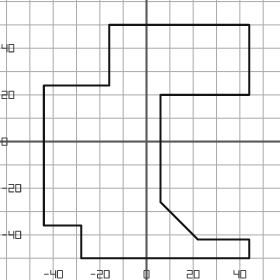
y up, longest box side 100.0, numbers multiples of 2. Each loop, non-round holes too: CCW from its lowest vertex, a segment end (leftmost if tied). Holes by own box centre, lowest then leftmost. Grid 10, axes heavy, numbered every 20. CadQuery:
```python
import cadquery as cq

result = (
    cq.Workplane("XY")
    .moveTo(-28.0, -50.0)
    .lineTo(44.0, -50.0)
    .lineTo(44.0, -42.0)
    .lineTo(22.0, -42.0)
    .lineTo(6.0, -26.0)
    .lineTo(6.0, 20.0)
    .lineTo(44.0, 20.0)
    .lineTo(44.0, 50.0)
    .lineTo(-16.0, 50.0)
    .lineTo(-16.0, 24.0)
    .lineTo(-44.0, 24.0)
    .lineTo(-44.0, -36.0)
    .lineTo(-28.0, -36.0)
    .close()
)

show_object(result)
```